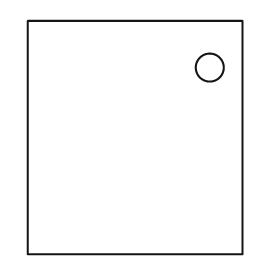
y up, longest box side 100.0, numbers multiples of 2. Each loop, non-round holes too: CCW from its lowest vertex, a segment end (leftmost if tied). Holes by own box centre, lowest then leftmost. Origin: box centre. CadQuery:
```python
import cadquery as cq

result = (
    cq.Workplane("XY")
    .moveTo(-46.0, -50.0)
    .lineTo(46.0, -50.0)
    .lineTo(46.0, 50.0)
    .lineTo(-46.0, 50.0)
    .close()
    .moveTo(32.0, 30.0)
    .circle(6.0)
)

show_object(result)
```